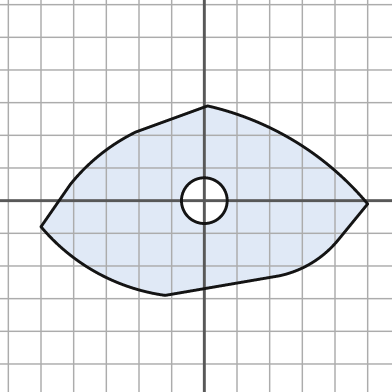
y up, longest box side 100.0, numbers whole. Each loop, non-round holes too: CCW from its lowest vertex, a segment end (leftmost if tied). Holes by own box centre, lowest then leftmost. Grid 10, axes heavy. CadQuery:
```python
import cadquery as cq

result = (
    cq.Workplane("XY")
    .moveTo(-12.0, -29.0)
    .lineTo(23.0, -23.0)
    .threePointArc((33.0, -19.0), (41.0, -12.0))
    .lineTo(50.0, -1.0)
    .threePointArc((28.0, 18.0), (1.0, 29.0))
    .lineTo(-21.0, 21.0)
    .threePointArc((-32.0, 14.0), (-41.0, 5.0))
    .lineTo(-50.0, -8.0)
    .threePointArc((-33.0, -22.0), (-12.0, -29.0))
    .close()
    .moveTo(0.0, 0.0)
    .circle(7.0)
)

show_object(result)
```